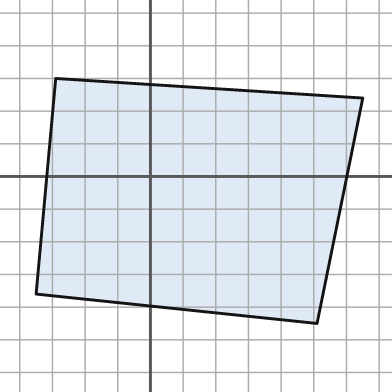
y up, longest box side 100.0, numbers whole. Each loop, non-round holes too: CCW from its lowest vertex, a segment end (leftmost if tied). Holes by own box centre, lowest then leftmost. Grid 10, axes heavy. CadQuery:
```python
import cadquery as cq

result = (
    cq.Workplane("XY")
    .moveTo(51.0, -45.0)
    .lineTo(65.0, 24.0)
    .lineTo(-29.0, 30.0)
    .lineTo(-35.0, -36.0)
    .close()
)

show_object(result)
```